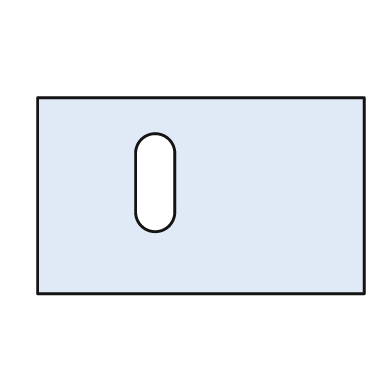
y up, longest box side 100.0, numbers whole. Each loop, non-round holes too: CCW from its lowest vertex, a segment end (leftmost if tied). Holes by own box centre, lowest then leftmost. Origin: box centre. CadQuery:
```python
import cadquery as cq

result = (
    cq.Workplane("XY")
    .moveTo(-50.0, -30.0)
    .lineTo(50.0, -30.0)
    .lineTo(50.0, 30.0)
    .lineTo(-50.0, 30.0)
    .close()
    .moveTo(-20.0, -5.0)
    .threePointArc((-14.0, -11.0), (-8.0, -5.0))
    .lineTo(-8.0, 13.0)
    .threePointArc((-14.0, 19.0), (-20.0, 13.0))
    .close()
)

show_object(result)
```